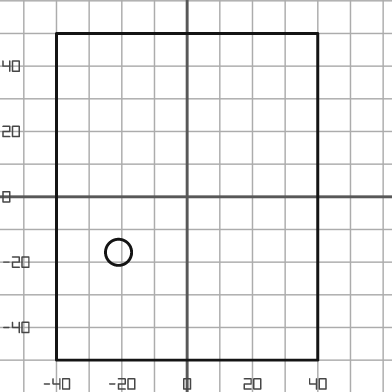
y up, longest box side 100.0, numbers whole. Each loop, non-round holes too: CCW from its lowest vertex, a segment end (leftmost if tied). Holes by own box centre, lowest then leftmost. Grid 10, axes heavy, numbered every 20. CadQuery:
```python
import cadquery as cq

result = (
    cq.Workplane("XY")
    .moveTo(-40.0, -50.0)
    .lineTo(40.0, -50.0)
    .lineTo(40.0, 50.0)
    .lineTo(-40.0, 50.0)
    .close()
    .moveTo(-21.0, -17.0)
    .circle(4.0)
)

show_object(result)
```